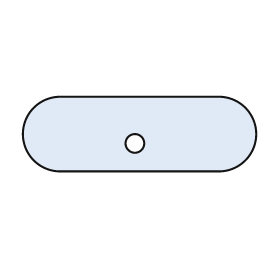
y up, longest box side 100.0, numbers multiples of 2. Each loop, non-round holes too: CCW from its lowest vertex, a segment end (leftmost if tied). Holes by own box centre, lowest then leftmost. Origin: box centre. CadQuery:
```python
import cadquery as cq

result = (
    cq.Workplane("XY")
    .moveTo(-34.0, -16.0)
    .lineTo(34.0, -16.0)
    .threePointArc((50.0, 0.0), (34.0, 16.0))
    .lineTo(-34.0, 16.0)
    .threePointArc((-50.0, 0.0), (-34.0, -16.0))
    .close()
    .moveTo(-2.0, -4.0)
    .circle(4.0)
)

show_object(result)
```